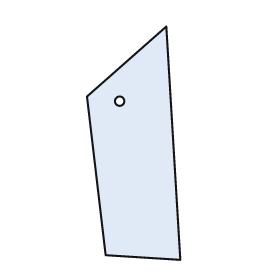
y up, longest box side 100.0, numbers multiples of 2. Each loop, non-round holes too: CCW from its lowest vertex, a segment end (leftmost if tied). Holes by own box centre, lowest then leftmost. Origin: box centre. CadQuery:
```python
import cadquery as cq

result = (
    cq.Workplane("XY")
    .moveTo(20.0, -50.0)
    .lineTo(14.0, 50.0)
    .lineTo(-20.0, 20.0)
    .lineTo(-12.0, -48.0)
    .close()
    .moveTo(-6.0, 18.0)
    .circle(2.0)
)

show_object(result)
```